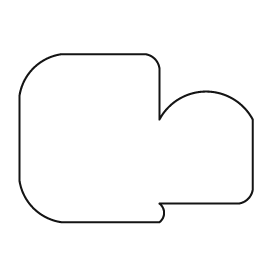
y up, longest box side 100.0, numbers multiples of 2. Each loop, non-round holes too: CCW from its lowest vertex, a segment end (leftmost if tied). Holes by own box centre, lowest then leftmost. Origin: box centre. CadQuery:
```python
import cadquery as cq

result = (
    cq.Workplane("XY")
    .moveTo(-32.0, -36.0)
    .lineTo(10.0, -36.0)
    .threePointArc((12.0, -32.0), (10.0, -28.0))
    .lineTo(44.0, -28.0)
    .threePointArc((48.0, -26.0), (50.0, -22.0))
    .lineTo(50.0, 8.0)
    .threePointArc((30.0, 20.0), (10.0, 8.0))
    .lineTo(10.0, 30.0)
    .threePointArc((8.0, 34.0), (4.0, 36.0))
    .lineTo(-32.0, 36.0)
    .threePointArc((-44.0, 30.0), (-50.0, 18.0))
    .lineTo(-50.0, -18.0)
    .threePointArc((-44.0, -30.0), (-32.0, -36.0))
    .close()
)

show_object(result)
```